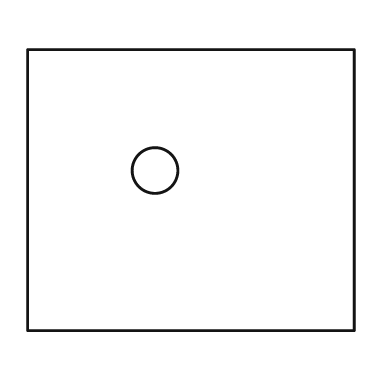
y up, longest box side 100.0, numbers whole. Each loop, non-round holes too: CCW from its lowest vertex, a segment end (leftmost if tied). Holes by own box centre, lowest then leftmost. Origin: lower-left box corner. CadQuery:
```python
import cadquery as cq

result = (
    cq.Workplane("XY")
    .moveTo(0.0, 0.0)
    .lineTo(100.0, 0.0)
    .lineTo(100.0, 86.0)
    .lineTo(0.0, 86.0)
    .close()
    .moveTo(39.0, 49.0)
    .circle(7.0)
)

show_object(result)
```